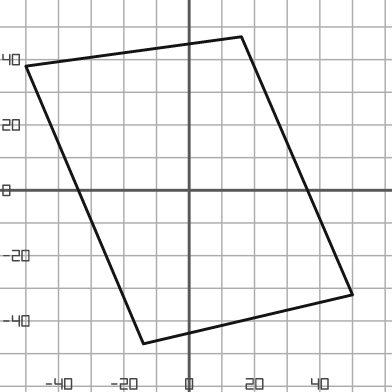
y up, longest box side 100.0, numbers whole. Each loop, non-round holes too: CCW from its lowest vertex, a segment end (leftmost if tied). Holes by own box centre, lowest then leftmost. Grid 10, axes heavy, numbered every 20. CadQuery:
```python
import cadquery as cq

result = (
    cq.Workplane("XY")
    .moveTo(-14.0, -47.0)
    .lineTo(50.0, -32.0)
    .lineTo(16.0, 47.0)
    .lineTo(-50.0, 38.0)
    .close()
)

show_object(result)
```